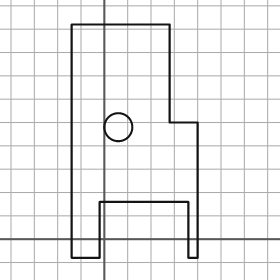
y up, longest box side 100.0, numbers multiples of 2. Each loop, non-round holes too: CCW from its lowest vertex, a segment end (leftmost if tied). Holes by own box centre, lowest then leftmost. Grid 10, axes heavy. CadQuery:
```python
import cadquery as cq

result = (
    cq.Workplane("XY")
    .moveTo(-14.0, -8.0)
    .lineTo(-2.0, -8.0)
    .lineTo(-2.0, 16.0)
    .lineTo(36.0, 16.0)
    .lineTo(36.0, -8.0)
    .lineTo(40.0, -8.0)
    .lineTo(40.0, 50.0)
    .lineTo(28.0, 50.0)
    .lineTo(28.0, 92.0)
    .lineTo(-14.0, 92.0)
    .close()
    .moveTo(6.0, 48.0)
    .circle(6.0)
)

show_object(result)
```